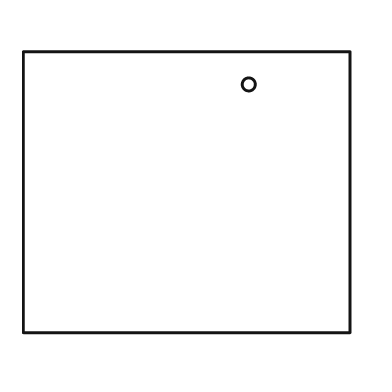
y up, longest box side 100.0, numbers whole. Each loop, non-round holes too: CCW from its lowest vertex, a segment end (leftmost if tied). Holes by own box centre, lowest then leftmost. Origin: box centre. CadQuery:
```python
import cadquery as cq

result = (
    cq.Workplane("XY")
    .moveTo(-50.0, -43.0)
    .lineTo(50.0, -43.0)
    .lineTo(50.0, 43.0)
    .lineTo(-50.0, 43.0)
    .close()
    .moveTo(19.0, 33.0)
    .circle(2.0)
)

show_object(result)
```